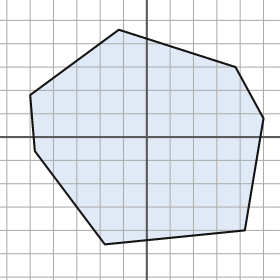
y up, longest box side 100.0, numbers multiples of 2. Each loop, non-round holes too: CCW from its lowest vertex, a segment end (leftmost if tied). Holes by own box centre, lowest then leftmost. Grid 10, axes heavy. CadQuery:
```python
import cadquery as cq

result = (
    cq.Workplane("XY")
    .moveTo(-18.0, -46.0)
    .lineTo(42.0, -40.0)
    .lineTo(50.0, 8.0)
    .lineTo(38.0, 30.0)
    .lineTo(-12.0, 46.0)
    .lineTo(-50.0, 18.0)
    .lineTo(-48.0, -6.0)
    .close()
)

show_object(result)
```